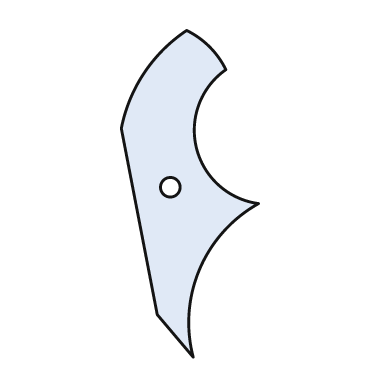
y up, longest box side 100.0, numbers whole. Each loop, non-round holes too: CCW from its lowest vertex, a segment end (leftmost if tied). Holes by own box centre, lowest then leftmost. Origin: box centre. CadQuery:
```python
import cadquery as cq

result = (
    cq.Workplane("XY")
    .moveTo(1.0, -50.0)
    .threePointArc((3.0, -23.0), (21.0, -3.0))
    .threePointArc((2.0, 14.0), (11.0, 38.0))
    .threePointArc((6.0, 45.0), (-1.0, 50.0))
    .threePointArc((-14.0, 37.0), (-21.0, 20.0))
    .lineTo(-10.0, -37.0)
    .close()
    .moveTo(-6.0, 2.0)
    .circle(3.0)
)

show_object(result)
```